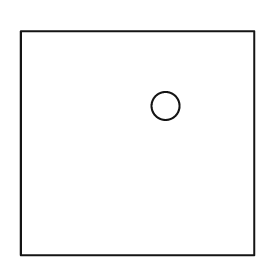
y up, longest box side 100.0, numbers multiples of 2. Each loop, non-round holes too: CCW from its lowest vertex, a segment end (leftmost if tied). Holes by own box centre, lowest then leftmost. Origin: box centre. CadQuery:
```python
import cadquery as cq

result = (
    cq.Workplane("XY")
    .moveTo(-50.0, -48.0)
    .lineTo(50.0, -48.0)
    .lineTo(50.0, 48.0)
    .lineTo(-50.0, 48.0)
    .close()
    .moveTo(12.0, 16.0)
    .circle(6.0)
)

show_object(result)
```